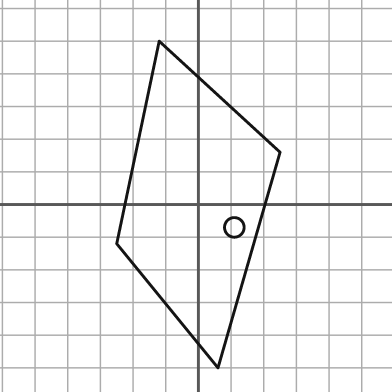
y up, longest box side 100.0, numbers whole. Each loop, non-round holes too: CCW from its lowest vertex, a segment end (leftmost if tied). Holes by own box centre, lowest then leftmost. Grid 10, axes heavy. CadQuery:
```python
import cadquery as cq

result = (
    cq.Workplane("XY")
    .moveTo(6.0, -50.0)
    .lineTo(25.0, 16.0)
    .lineTo(-12.0, 50.0)
    .lineTo(-25.0, -12.0)
    .close()
    .moveTo(11.0, -7.0)
    .circle(3.0)
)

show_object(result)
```